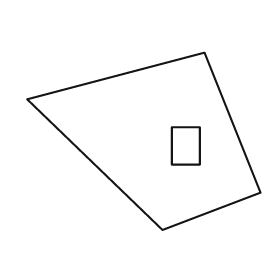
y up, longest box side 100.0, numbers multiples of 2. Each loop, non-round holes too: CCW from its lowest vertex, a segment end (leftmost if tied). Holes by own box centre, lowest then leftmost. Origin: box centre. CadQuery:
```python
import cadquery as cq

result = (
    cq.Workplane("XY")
    .moveTo(8.0, -38.0)
    .lineTo(50.0, -22.0)
    .lineTo(26.0, 38.0)
    .lineTo(-50.0, 18.0)
    .close()
    .moveTo(12.0, -10.0)
    .lineTo(24.0, -10.0)
    .lineTo(24.0, 6.0)
    .lineTo(12.0, 6.0)
    .close()
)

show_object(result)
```